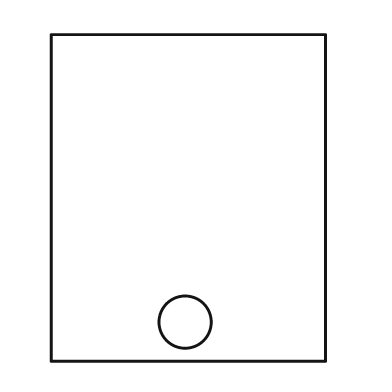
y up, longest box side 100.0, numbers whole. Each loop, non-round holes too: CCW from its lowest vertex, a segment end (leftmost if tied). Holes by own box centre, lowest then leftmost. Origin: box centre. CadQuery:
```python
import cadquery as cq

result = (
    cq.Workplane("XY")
    .moveTo(-42.0, -50.0)
    .lineTo(42.0, -50.0)
    .lineTo(42.0, 50.0)
    .lineTo(-42.0, 50.0)
    .close()
    .moveTo(-1.0, -38.0)
    .circle(8.0)
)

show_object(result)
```